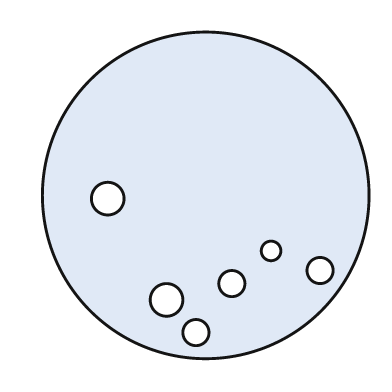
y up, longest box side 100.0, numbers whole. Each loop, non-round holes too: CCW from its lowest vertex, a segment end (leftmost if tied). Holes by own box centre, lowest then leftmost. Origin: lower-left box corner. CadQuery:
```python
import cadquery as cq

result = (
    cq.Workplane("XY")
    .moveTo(50.0, 50.0)
    .circle(50.0)
    .moveTo(47.0, 8.0)
    .circle(4.0)
    .moveTo(38.0, 18.0)
    .circle(5.0)
    .moveTo(58.0, 23.0)
    .circle(4.0)
    .moveTo(85.0, 27.0)
    .circle(4.0)
    .moveTo(70.0, 33.0)
    .circle(3.0)
    .moveTo(20.0, 49.0)
    .circle(5.0)
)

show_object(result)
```